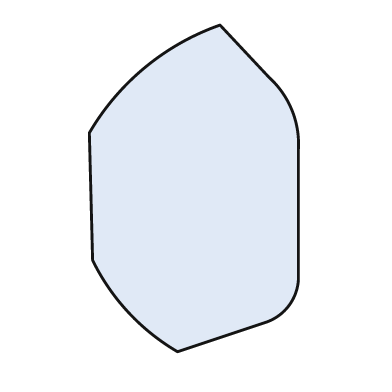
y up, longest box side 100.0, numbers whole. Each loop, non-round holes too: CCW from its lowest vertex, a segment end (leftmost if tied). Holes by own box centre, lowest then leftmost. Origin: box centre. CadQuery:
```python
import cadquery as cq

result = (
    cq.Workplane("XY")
    .moveTo(-5.0, -50.0)
    .lineTo(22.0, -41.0)
    .threePointArc((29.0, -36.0), (32.0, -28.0))
    .lineTo(32.0, 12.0)
    .threePointArc((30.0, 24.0), (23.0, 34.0))
    .lineTo(8.0, 50.0)
    .threePointArc((-15.0, 37.0), (-32.0, 17.0))
    .lineTo(-31.0, -22.0)
    .threePointArc((-20.0, -38.0), (-5.0, -50.0))
    .close()
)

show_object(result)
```